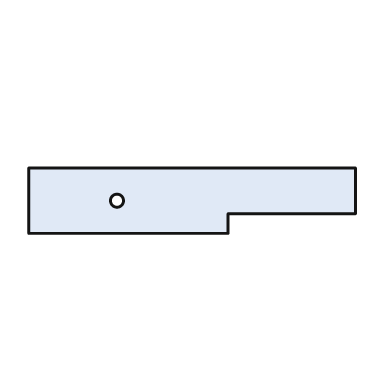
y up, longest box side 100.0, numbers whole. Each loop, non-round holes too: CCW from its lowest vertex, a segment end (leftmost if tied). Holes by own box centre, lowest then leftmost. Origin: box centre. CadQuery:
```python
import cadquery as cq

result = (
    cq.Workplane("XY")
    .moveTo(-50.0, -10.0)
    .lineTo(11.0, -10.0)
    .lineTo(11.0, -4.0)
    .lineTo(50.0, -4.0)
    .lineTo(50.0, 10.0)
    .lineTo(-50.0, 10.0)
    .close()
    .moveTo(-23.0, 0.0)
    .circle(2.0)
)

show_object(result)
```